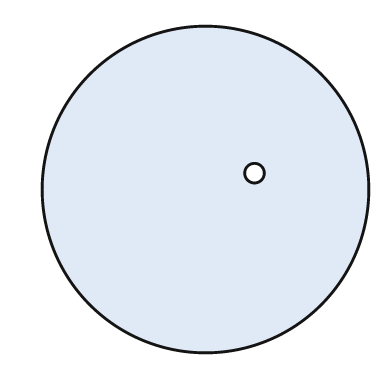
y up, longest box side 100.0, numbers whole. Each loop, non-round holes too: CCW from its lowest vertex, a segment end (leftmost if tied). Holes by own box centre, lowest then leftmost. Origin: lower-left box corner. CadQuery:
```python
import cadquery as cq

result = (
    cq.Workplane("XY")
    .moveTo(50.0, 50.0)
    .circle(50.0)
    .moveTo(65.0, 55.0)
    .circle(3.0)
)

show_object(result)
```